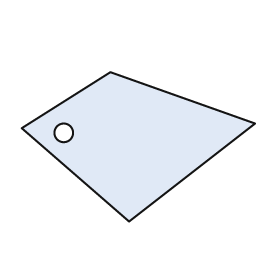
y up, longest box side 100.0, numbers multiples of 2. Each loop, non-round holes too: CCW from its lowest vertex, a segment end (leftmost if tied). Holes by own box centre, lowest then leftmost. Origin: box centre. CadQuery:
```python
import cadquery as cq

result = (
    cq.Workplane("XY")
    .moveTo(-4.0, -32.0)
    .lineTo(50.0, 10.0)
    .lineTo(-12.0, 32.0)
    .lineTo(-50.0, 8.0)
    .close()
    .moveTo(-32.0, 6.0)
    .circle(4.0)
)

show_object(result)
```